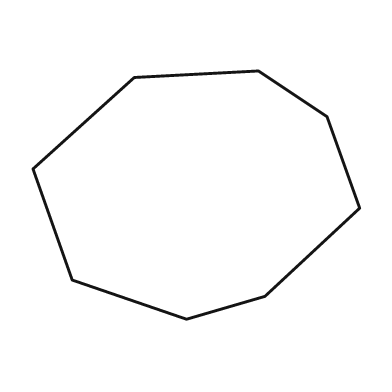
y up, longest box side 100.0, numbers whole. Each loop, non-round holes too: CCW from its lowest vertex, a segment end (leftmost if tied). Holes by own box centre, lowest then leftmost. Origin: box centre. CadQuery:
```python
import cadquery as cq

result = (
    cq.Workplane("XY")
    .moveTo(-3.0, -38.0)
    .lineTo(21.0, -31.0)
    .lineTo(50.0, -4.0)
    .lineTo(40.0, 24.0)
    .lineTo(19.0, 38.0)
    .lineTo(-19.0, 36.0)
    .lineTo(-50.0, 8.0)
    .lineTo(-38.0, -26.0)
    .close()
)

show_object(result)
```